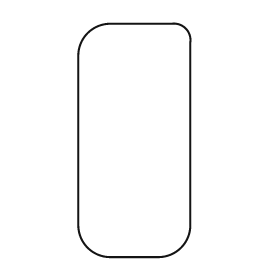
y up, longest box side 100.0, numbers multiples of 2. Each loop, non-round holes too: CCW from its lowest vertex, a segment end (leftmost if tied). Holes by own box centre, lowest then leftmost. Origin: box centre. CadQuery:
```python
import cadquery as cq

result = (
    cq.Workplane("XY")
    .moveTo(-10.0, -50.0)
    .lineTo(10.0, -50.0)
    .threePointArc((20.0, -46.0), (24.0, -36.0))
    .lineTo(24.0, 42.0)
    .threePointArc((22.0, 48.0), (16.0, 50.0))
    .lineTo(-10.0, 50.0)
    .threePointArc((-20.0, 46.0), (-24.0, 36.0))
    .lineTo(-24.0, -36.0)
    .threePointArc((-20.0, -46.0), (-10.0, -50.0))
    .close()
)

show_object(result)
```